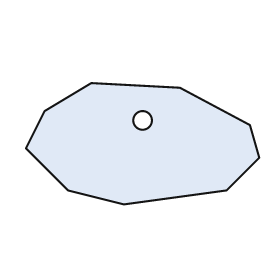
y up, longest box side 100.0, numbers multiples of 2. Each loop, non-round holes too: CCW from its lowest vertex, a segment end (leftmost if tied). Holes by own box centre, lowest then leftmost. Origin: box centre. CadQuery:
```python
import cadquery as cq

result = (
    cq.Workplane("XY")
    .moveTo(-8.0, -26.0)
    .lineTo(36.0, -20.0)
    .lineTo(50.0, -6.0)
    .lineTo(46.0, 8.0)
    .lineTo(16.0, 24.0)
    .lineTo(-22.0, 26.0)
    .lineTo(-42.0, 14.0)
    .lineTo(-50.0, -2.0)
    .lineTo(-32.0, -20.0)
    .close()
    .moveTo(0.0, 10.0)
    .circle(4.0)
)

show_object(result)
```